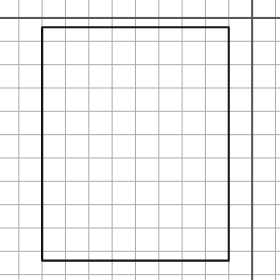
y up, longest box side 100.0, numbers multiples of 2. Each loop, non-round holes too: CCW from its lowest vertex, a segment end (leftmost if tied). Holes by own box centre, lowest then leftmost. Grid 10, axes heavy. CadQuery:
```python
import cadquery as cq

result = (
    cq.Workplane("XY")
    .moveTo(-90.0, -104.0)
    .lineTo(-10.0, -104.0)
    .lineTo(-10.0, -4.0)
    .lineTo(-90.0, -4.0)
    .close()
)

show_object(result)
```